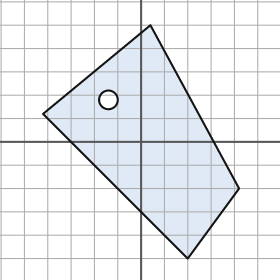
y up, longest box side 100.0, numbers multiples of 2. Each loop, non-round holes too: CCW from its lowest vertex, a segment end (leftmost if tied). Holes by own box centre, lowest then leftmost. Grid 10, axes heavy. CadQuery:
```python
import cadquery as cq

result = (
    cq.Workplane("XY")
    .moveTo(20.0, -50.0)
    .lineTo(42.0, -20.0)
    .lineTo(4.0, 50.0)
    .lineTo(-42.0, 12.0)
    .close()
    .moveTo(-14.0, 18.0)
    .circle(4.0)
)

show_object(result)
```